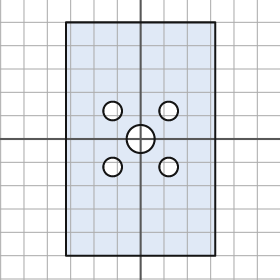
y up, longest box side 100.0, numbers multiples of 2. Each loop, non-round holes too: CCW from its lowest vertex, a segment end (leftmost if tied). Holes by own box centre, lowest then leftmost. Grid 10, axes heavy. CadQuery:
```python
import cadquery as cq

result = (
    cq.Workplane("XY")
    .moveTo(-32.0, -50.0)
    .lineTo(32.0, -50.0)
    .lineTo(32.0, 50.0)
    .lineTo(-32.0, 50.0)
    .close()
    .moveTo(-12.0, -12.0)
    .circle(4.0)
    .moveTo(12.0, -12.0)
    .circle(4.0)
    .moveTo(0.0, 0.0)
    .circle(6.0)
    .moveTo(-12.0, 12.0)
    .circle(4.0)
    .moveTo(12.0, 12.0)
    .circle(4.0)
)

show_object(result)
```